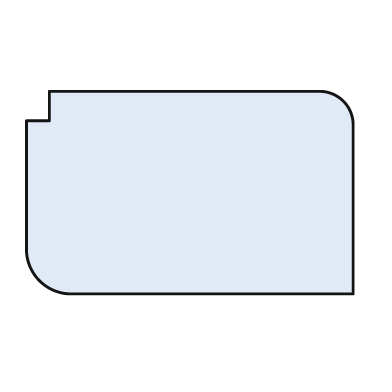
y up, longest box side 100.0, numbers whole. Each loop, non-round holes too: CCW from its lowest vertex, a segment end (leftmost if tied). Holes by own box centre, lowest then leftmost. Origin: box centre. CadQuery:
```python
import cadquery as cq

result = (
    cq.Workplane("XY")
    .moveTo(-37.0, -31.0)
    .lineTo(50.0, -31.0)
    .lineTo(50.0, 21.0)
    .threePointArc((47.0, 28.0), (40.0, 31.0))
    .lineTo(-43.0, 31.0)
    .lineTo(-43.0, 22.0)
    .lineTo(-50.0, 22.0)
    .lineTo(-50.0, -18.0)
    .threePointArc((-46.0, -27.0), (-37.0, -31.0))
    .close()
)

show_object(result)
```